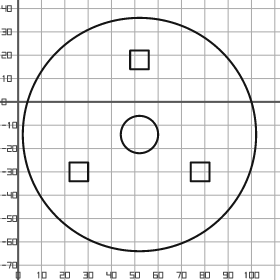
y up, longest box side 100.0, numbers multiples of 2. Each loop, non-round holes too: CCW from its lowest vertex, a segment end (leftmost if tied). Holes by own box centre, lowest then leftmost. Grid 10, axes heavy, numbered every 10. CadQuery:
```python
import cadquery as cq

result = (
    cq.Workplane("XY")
    .moveTo(52.0, -14.0)
    .circle(50.0)
    .moveTo(22.0, -34.0)
    .lineTo(30.0, -34.0)
    .lineTo(30.0, -26.0)
    .lineTo(22.0, -26.0)
    .close()
    .moveTo(74.0, -34.0)
    .lineTo(82.0, -34.0)
    .lineTo(82.0, -26.0)
    .lineTo(74.0, -26.0)
    .close()
    .moveTo(52.0, -14.0)
    .circle(8.0)
    .moveTo(48.0, 14.0)
    .lineTo(56.0, 14.0)
    .lineTo(56.0, 22.0)
    .lineTo(48.0, 22.0)
    .close()
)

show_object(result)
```